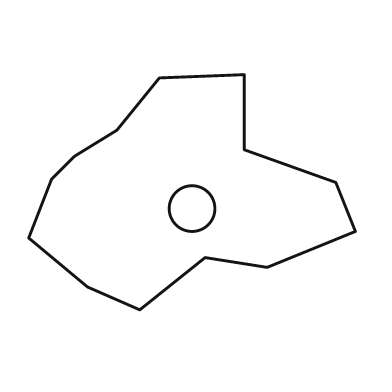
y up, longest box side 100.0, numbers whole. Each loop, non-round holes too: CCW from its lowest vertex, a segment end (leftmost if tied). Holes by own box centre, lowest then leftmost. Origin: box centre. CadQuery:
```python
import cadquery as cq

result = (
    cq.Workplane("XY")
    .moveTo(-16.0, -36.0)
    .lineTo(4.0, -20.0)
    .lineTo(23.0, -23.0)
    .lineTo(50.0, -12.0)
    .lineTo(44.0, 3.0)
    .lineTo(16.0, 13.0)
    .lineTo(16.0, 36.0)
    .lineTo(-10.0, 35.0)
    .lineTo(-23.0, 19.0)
    .lineTo(-36.0, 11.0)
    .lineTo(-43.0, 4.0)
    .lineTo(-50.0, -14.0)
    .lineTo(-32.0, -29.0)
    .close()
    .moveTo(0.0, -5.0)
    .circle(7.0)
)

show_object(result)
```